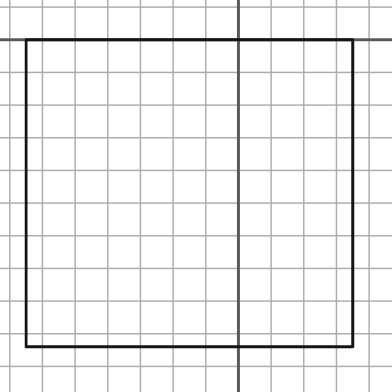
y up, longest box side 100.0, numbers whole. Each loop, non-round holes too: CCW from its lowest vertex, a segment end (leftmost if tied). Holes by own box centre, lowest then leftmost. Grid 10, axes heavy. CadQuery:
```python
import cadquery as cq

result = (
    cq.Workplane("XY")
    .moveTo(-65.0, -94.0)
    .lineTo(35.0, -94.0)
    .lineTo(35.0, 0.0)
    .lineTo(-65.0, 0.0)
    .close()
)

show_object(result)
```